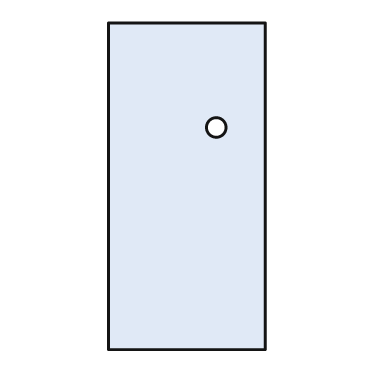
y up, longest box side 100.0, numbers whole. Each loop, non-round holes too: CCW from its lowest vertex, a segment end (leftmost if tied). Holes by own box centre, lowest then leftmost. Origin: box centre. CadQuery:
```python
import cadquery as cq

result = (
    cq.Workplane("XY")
    .moveTo(-24.0, -50.0)
    .lineTo(24.0, -50.0)
    .lineTo(24.0, 50.0)
    .lineTo(-24.0, 50.0)
    .close()
    .moveTo(9.0, 18.0)
    .circle(3.0)
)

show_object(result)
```